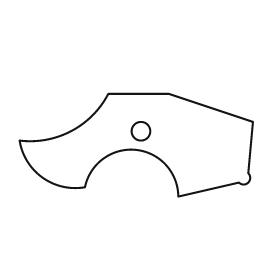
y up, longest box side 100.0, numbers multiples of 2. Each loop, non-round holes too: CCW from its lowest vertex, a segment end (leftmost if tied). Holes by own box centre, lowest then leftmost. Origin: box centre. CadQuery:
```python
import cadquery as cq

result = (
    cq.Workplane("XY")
    .moveTo(18.0, -22.0)
    .lineTo(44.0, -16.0)
    .threePointArc((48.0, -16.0), (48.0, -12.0))
    .lineTo(50.0, 10.0)
    .lineTo(14.0, 22.0)
    .lineTo(-12.0, 22.0)
    .threePointArc((-28.0, 6.0), (-50.0, 2.0))
    .threePointArc((-40.0, -14.0), (-22.0, -18.0))
    .threePointArc((0.0, -2.0), (18.0, -22.0))
    .close()
    .moveTo(2.0, 6.0)
    .circle(4.0)
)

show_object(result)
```